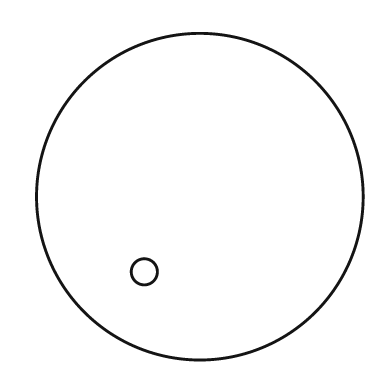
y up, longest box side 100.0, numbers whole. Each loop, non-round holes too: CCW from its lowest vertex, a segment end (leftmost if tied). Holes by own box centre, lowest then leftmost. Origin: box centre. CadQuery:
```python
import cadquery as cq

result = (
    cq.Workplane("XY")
    .moveTo(0.0, 0.0)
    .circle(50.0)
    .moveTo(-17.0, -23.0)
    .circle(4.0)
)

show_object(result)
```